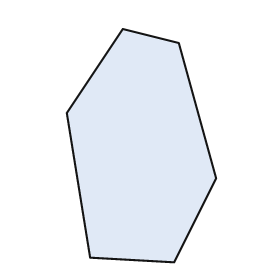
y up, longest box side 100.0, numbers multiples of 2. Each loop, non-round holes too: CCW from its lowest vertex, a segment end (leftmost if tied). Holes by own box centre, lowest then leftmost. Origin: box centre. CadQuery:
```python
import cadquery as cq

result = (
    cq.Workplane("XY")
    .moveTo(14.0, -50.0)
    .lineTo(32.0, -14.0)
    .lineTo(16.0, 44.0)
    .lineTo(-8.0, 50.0)
    .lineTo(-32.0, 14.0)
    .lineTo(-22.0, -48.0)
    .close()
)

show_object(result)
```